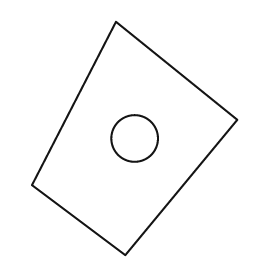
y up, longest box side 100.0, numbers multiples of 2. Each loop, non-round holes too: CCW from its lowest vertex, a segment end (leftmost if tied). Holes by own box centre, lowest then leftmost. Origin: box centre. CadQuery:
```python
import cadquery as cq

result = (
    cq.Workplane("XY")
    .moveTo(-4.0, -50.0)
    .lineTo(44.0, 8.0)
    .lineTo(-8.0, 50.0)
    .lineTo(-44.0, -20.0)
    .close()
    .moveTo(0.0, 0.0)
    .circle(10.0)
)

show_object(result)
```